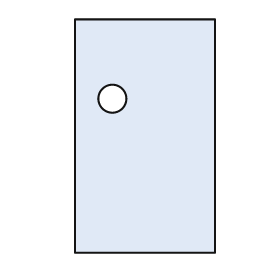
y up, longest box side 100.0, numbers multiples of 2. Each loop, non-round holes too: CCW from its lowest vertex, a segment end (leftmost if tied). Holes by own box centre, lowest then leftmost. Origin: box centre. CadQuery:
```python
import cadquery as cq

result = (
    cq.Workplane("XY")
    .moveTo(-30.0, -50.0)
    .lineTo(30.0, -50.0)
    .lineTo(30.0, 50.0)
    .lineTo(-30.0, 50.0)
    .close()
    .moveTo(-14.0, 16.0)
    .circle(6.0)
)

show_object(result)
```